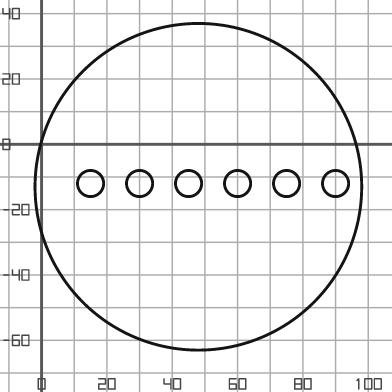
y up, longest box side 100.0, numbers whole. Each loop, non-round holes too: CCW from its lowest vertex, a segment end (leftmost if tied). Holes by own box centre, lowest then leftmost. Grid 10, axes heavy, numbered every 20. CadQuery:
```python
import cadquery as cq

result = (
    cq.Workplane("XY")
    .moveTo(48.0, -13.0)
    .circle(50.0)
    .moveTo(15.0, -12.0)
    .circle(4.0)
    .moveTo(30.0, -12.0)
    .circle(4.0)
    .moveTo(45.0, -12.0)
    .circle(4.0)
    .moveTo(60.0, -12.0)
    .circle(4.0)
    .moveTo(75.0, -12.0)
    .circle(4.0)
    .moveTo(90.0, -12.0)
    .circle(4.0)
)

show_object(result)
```